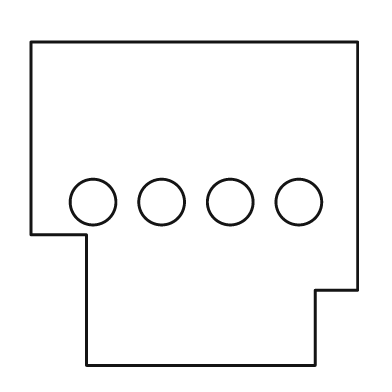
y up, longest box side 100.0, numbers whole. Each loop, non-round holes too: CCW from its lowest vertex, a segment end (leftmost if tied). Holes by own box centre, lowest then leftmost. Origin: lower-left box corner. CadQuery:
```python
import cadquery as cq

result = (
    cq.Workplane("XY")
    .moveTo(17.0, 0.0)
    .lineTo(87.0, 0.0)
    .lineTo(87.0, 23.0)
    .lineTo(100.0, 23.0)
    .lineTo(100.0, 99.0)
    .lineTo(0.0, 99.0)
    .lineTo(0.0, 40.0)
    .lineTo(17.0, 40.0)
    .close()
    .moveTo(19.0, 50.0)
    .circle(7.0)
    .moveTo(40.0, 50.0)
    .circle(7.0)
    .moveTo(61.0, 50.0)
    .circle(7.0)
    .moveTo(82.0, 50.0)
    .circle(7.0)
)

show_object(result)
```